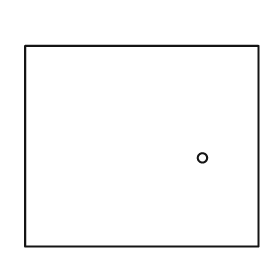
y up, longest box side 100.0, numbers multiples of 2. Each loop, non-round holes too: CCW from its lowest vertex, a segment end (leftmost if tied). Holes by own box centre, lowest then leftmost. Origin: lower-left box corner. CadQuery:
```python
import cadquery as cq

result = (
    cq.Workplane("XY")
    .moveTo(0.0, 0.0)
    .lineTo(100.0, 0.0)
    .lineTo(100.0, 86.0)
    .lineTo(0.0, 86.0)
    .close()
    .moveTo(76.0, 38.0)
    .circle(2.0)
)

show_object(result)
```